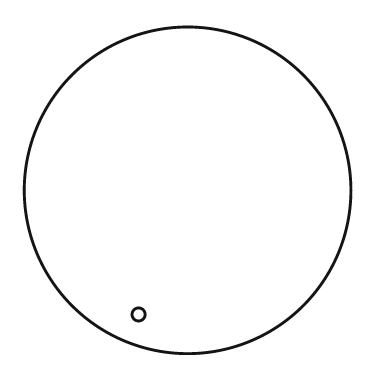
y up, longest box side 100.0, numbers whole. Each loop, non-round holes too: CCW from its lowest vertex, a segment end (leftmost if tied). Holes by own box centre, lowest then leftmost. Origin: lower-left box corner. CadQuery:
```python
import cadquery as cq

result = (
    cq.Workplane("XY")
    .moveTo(50.0, 50.0)
    .circle(50.0)
    .moveTo(35.0, 12.0)
    .circle(2.0)
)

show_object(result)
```